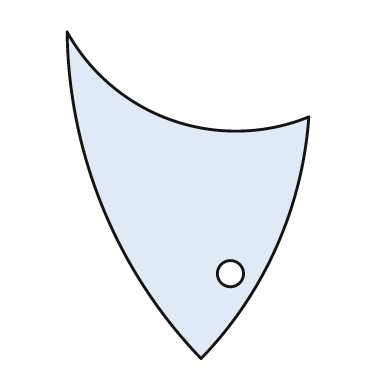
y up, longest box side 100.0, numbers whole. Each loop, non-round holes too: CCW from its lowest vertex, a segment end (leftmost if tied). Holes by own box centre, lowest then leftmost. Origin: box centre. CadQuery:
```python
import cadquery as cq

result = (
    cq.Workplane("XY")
    .moveTo(4.0, -50.0)
    .threePointArc((27.0, -16.0), (37.0, 24.0))
    .threePointArc((-5.0, 23.0), (-37.0, 50.0))
    .threePointArc((-26.0, -4.0), (4.0, -50.0))
    .close()
    .moveTo(13.0, -24.0)
    .circle(4.0)
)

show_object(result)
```